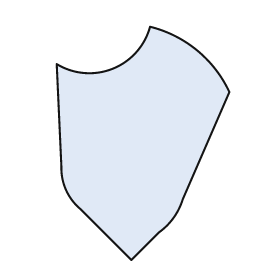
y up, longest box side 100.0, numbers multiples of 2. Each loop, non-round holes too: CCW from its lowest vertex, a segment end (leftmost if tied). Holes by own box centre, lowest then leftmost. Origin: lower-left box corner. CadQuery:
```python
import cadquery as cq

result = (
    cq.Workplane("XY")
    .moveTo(32.0, 0.0)
    .lineTo(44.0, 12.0)
    .threePointArc((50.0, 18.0), (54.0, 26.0))
    .lineTo(74.0, 72.0)
    .threePointArc((60.0, 90.0), (40.0, 100.0))
    .threePointArc((24.0, 82.0), (0.0, 84.0))
    .lineTo(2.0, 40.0)
    .threePointArc((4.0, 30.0), (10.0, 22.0))
    .close()
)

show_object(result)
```